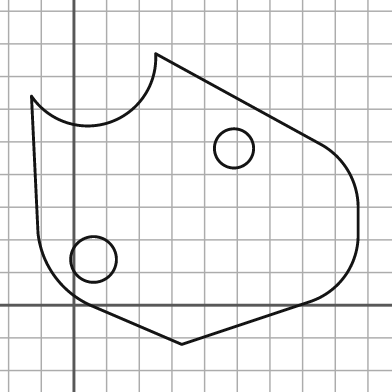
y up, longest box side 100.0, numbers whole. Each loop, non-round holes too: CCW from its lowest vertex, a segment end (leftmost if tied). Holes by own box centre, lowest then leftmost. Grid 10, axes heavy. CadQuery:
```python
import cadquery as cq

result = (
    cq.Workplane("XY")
    .moveTo(33.0, -12.0)
    .lineTo(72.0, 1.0)
    .threePointArc((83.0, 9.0), (87.0, 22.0))
    .lineTo(87.0, 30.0)
    .threePointArc((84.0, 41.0), (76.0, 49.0))
    .lineTo(25.0, 77.0)
    .threePointArc((11.0, 56.0), (-13.0, 64.0))
    .lineTo(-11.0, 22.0)
    .threePointArc((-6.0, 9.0), (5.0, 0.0))
    .close()
    .moveTo(6.0, 14.0)
    .circle(7.0)
    .moveTo(49.0, 48.0)
    .circle(6.0)
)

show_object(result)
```